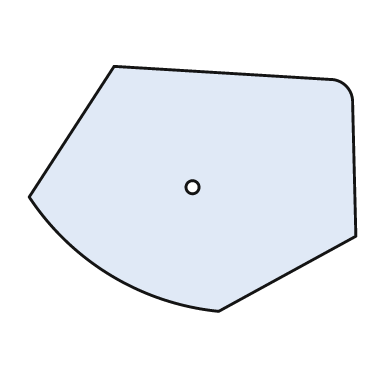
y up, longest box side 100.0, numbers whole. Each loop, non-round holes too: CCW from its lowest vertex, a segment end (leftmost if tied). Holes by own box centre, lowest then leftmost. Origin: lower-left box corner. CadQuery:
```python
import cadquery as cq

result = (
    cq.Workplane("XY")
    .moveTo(58.0, 0.0)
    .lineTo(100.0, 23.0)
    .lineTo(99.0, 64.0)
    .threePointArc((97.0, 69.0), (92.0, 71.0))
    .lineTo(26.0, 75.0)
    .lineTo(0.0, 35.0)
    .threePointArc((25.0, 11.0), (58.0, 0.0))
    .close()
    .moveTo(50.0, 38.0)
    .circle(2.0)
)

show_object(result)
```